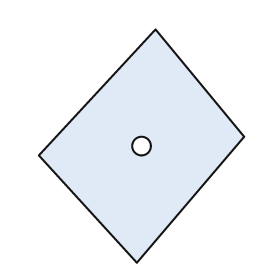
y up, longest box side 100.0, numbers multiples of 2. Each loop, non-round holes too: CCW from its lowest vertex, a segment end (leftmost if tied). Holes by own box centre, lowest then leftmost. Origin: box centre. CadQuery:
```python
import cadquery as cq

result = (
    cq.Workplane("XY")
    .moveTo(-2.0, -50.0)
    .lineTo(44.0, 4.0)
    .lineTo(6.0, 50.0)
    .lineTo(-44.0, -4.0)
    .close()
    .moveTo(0.0, 0.0)
    .circle(4.0)
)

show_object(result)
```